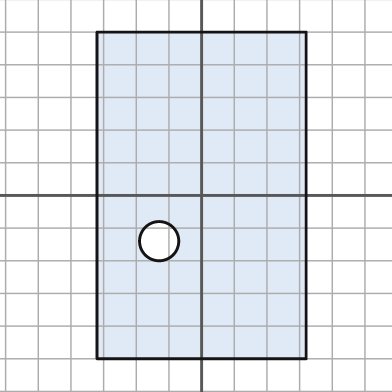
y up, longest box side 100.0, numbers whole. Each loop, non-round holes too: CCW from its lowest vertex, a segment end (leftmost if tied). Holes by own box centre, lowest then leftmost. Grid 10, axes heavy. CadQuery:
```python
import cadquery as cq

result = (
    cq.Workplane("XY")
    .moveTo(-32.0, -50.0)
    .lineTo(32.0, -50.0)
    .lineTo(32.0, 50.0)
    .lineTo(-32.0, 50.0)
    .close()
    .moveTo(-13.0, -14.0)
    .circle(6.0)
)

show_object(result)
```